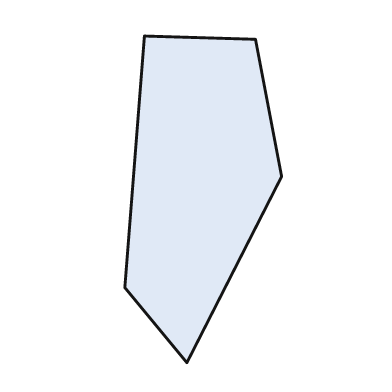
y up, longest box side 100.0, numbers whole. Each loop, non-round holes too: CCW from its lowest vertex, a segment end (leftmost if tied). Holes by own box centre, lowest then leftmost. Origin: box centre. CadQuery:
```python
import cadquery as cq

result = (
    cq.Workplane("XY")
    .moveTo(-5.0, -50.0)
    .lineTo(24.0, 7.0)
    .lineTo(16.0, 49.0)
    .lineTo(-18.0, 50.0)
    .lineTo(-24.0, -27.0)
    .close()
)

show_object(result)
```